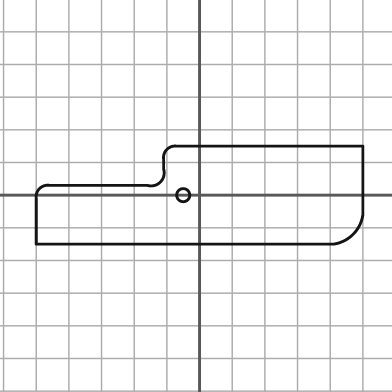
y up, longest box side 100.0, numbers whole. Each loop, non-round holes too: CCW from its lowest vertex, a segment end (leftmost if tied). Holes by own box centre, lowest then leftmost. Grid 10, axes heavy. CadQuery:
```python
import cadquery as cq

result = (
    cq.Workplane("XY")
    .moveTo(-50.0, -15.0)
    .lineTo(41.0, -15.0)
    .threePointArc((47.0, -12.0), (50.0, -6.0))
    .lineTo(50.0, 15.0)
    .lineTo(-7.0, 15.0)
    .threePointArc((-10.0, 14.0), (-11.0, 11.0))
    .lineTo(-11.0, 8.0)
    .threePointArc((-12.0, 4.0), (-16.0, 3.0))
    .lineTo(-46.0, 3.0)
    .threePointArc((-49.0, 2.0), (-50.0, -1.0))
    .close()
    .moveTo(-5.0, 0.0)
    .circle(2.0)
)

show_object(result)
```